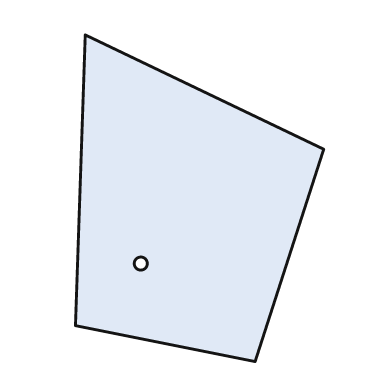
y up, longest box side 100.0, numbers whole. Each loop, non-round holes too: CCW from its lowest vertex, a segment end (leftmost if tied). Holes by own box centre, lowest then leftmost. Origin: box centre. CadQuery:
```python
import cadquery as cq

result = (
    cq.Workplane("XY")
    .moveTo(17.0, -50.0)
    .lineTo(38.0, 15.0)
    .lineTo(-35.0, 50.0)
    .lineTo(-38.0, -39.0)
    .close()
    .moveTo(-18.0, -20.0)
    .circle(2.0)
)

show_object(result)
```